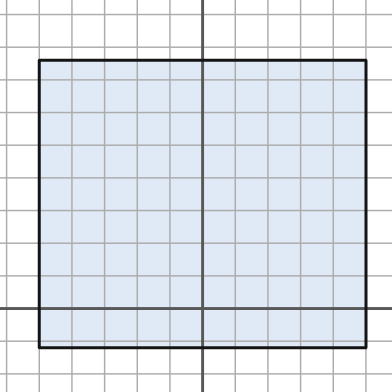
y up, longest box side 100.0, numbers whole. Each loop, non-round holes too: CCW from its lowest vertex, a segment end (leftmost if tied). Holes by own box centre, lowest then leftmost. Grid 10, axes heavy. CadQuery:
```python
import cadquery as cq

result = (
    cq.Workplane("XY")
    .moveTo(-50.0, -12.0)
    .lineTo(50.0, -12.0)
    .lineTo(50.0, 76.0)
    .lineTo(-50.0, 76.0)
    .close()
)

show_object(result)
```